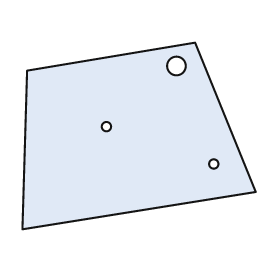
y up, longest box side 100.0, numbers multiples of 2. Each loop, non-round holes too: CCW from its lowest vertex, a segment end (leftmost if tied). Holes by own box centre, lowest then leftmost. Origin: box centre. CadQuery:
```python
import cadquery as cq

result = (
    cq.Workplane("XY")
    .moveTo(-50.0, -40.0)
    .lineTo(50.0, -24.0)
    .lineTo(24.0, 40.0)
    .lineTo(-48.0, 28.0)
    .close()
    .moveTo(32.0, -12.0)
    .circle(2.0)
    .moveTo(-14.0, 4.0)
    .circle(2.0)
    .moveTo(16.0, 30.0)
    .circle(4.0)
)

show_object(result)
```